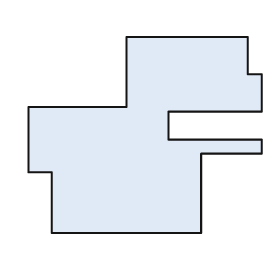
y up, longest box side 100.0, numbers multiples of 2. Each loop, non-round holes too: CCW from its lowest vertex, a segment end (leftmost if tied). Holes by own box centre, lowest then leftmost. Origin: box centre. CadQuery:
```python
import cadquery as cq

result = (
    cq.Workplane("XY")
    .moveTo(-40.0, -42.0)
    .lineTo(24.0, -42.0)
    .lineTo(24.0, -8.0)
    .lineTo(50.0, -8.0)
    .lineTo(50.0, -2.0)
    .lineTo(10.0, -2.0)
    .lineTo(10.0, 10.0)
    .lineTo(50.0, 10.0)
    .lineTo(50.0, 26.0)
    .lineTo(44.0, 26.0)
    .lineTo(44.0, 42.0)
    .lineTo(-8.0, 42.0)
    .lineTo(-8.0, 12.0)
    .lineTo(-50.0, 12.0)
    .lineTo(-50.0, -16.0)
    .lineTo(-40.0, -16.0)
    .close()
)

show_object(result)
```